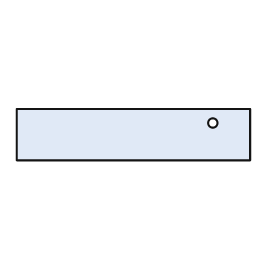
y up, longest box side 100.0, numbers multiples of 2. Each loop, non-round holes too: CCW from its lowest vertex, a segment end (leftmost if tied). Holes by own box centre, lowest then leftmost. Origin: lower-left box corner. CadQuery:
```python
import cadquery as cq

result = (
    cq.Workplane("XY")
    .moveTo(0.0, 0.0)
    .lineTo(100.0, 0.0)
    .lineTo(100.0, 22.0)
    .lineTo(0.0, 22.0)
    .close()
    .moveTo(84.0, 16.0)
    .circle(2.0)
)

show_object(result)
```